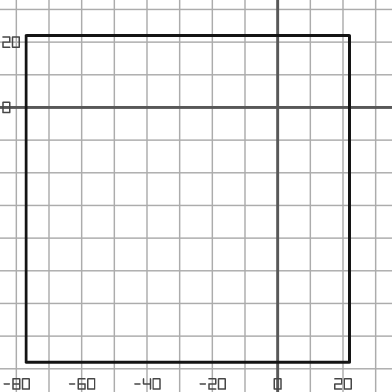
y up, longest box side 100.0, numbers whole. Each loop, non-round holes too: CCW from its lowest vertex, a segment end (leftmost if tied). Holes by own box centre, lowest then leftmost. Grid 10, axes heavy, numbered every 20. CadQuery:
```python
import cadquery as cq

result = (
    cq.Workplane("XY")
    .moveTo(-77.0, -78.0)
    .lineTo(22.0, -78.0)
    .lineTo(22.0, 22.0)
    .lineTo(-77.0, 22.0)
    .close()
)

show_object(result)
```